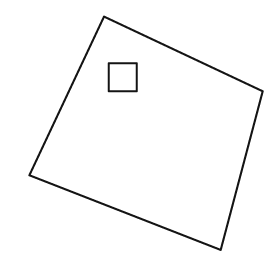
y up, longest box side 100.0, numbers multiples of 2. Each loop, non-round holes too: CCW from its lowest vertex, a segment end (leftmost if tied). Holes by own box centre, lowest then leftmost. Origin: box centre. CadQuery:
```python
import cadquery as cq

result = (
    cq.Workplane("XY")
    .moveTo(32.0, -50.0)
    .lineTo(50.0, 18.0)
    .lineTo(-18.0, 50.0)
    .lineTo(-50.0, -18.0)
    .close()
    .moveTo(-16.0, 18.0)
    .lineTo(-4.0, 18.0)
    .lineTo(-4.0, 30.0)
    .lineTo(-16.0, 30.0)
    .close()
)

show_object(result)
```